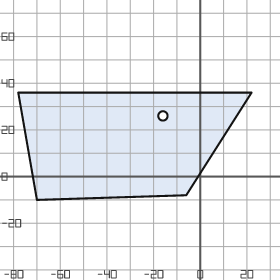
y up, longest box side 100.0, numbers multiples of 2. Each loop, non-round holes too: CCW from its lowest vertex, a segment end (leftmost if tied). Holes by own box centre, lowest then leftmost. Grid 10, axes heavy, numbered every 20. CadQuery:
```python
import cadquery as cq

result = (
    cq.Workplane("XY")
    .moveTo(-70.0, -10.0)
    .lineTo(-6.0, -8.0)
    .lineTo(22.0, 36.0)
    .lineTo(-78.0, 36.0)
    .close()
    .moveTo(-16.0, 26.0)
    .circle(2.0)
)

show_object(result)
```